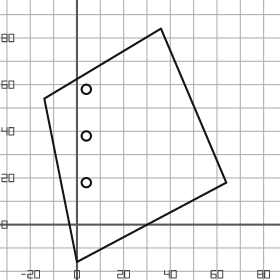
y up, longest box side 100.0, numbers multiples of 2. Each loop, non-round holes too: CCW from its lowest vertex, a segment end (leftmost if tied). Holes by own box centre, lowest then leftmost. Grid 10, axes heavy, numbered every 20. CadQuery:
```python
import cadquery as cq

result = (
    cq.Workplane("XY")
    .moveTo(0.0, -16.0)
    .lineTo(64.0, 18.0)
    .lineTo(36.0, 84.0)
    .lineTo(-14.0, 54.0)
    .close()
    .moveTo(4.0, 18.0)
    .circle(2.0)
    .moveTo(4.0, 38.0)
    .circle(2.0)
    .moveTo(4.0, 58.0)
    .circle(2.0)
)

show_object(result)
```